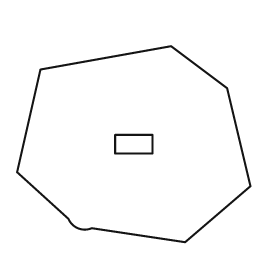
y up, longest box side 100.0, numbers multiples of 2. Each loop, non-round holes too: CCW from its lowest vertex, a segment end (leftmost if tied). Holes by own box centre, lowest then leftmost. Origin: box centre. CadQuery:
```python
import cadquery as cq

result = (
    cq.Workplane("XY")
    .moveTo(22.0, -42.0)
    .lineTo(50.0, -18.0)
    .lineTo(40.0, 24.0)
    .lineTo(16.0, 42.0)
    .lineTo(-40.0, 32.0)
    .lineTo(-50.0, -12.0)
    .lineTo(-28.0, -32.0)
    .threePointArc((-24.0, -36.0), (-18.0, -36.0))
    .close()
    .moveTo(-8.0, -4.0)
    .lineTo(8.0, -4.0)
    .lineTo(8.0, 4.0)
    .lineTo(-8.0, 4.0)
    .close()
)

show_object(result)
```